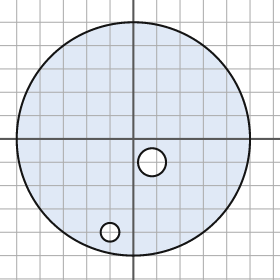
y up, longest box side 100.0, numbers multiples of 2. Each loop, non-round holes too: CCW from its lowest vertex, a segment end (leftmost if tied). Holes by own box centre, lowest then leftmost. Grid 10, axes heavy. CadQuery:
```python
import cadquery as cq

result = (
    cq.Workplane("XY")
    .moveTo(0.0, 0.0)
    .circle(50.0)
    .moveTo(-10.0, -40.0)
    .circle(4.0)
    .moveTo(8.0, -10.0)
    .circle(6.0)
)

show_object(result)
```